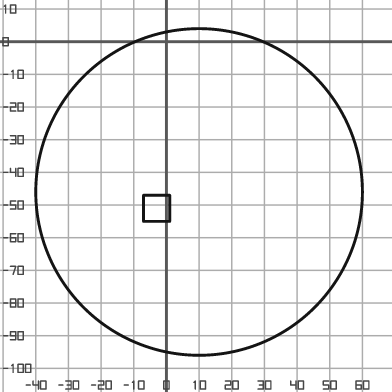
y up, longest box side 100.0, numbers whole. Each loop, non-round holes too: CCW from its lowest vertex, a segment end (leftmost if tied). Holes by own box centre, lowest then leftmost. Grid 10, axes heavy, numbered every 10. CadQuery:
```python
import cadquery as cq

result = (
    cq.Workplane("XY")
    .moveTo(10.0, -46.0)
    .circle(50.0)
    .moveTo(-7.0, -55.0)
    .lineTo(1.0, -55.0)
    .lineTo(1.0, -47.0)
    .lineTo(-7.0, -47.0)
    .close()
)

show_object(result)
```